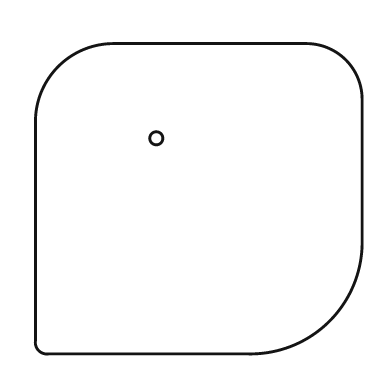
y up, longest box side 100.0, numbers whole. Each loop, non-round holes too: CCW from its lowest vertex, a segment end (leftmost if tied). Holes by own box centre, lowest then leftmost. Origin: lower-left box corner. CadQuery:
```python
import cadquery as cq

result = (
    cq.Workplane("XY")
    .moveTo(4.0, 0.0)
    .lineTo(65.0, 0.0)
    .threePointArc((90.0, 10.0), (100.0, 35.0))
    .lineTo(100.0, 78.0)
    .threePointArc((95.0, 90.0), (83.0, 95.0))
    .lineTo(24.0, 95.0)
    .threePointArc((7.0, 88.0), (0.0, 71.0))
    .lineTo(0.0, 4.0)
    .threePointArc((1.0, 1.0), (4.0, 0.0))
    .close()
    .moveTo(37.0, 66.0)
    .circle(2.0)
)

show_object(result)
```